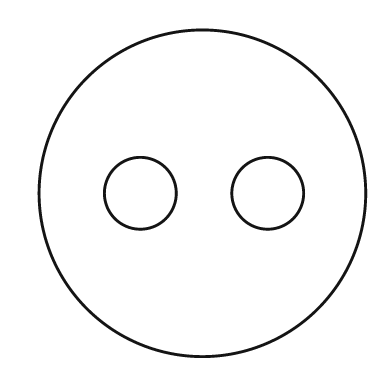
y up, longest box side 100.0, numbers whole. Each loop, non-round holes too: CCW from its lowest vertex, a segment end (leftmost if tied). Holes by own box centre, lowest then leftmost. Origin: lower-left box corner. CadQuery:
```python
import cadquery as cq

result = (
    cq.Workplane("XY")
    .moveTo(50.0, 50.0)
    .circle(50.0)
    .moveTo(31.0, 50.0)
    .circle(11.0)
    .moveTo(70.0, 50.0)
    .circle(11.0)
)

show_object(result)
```